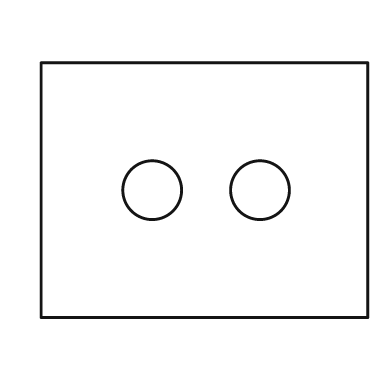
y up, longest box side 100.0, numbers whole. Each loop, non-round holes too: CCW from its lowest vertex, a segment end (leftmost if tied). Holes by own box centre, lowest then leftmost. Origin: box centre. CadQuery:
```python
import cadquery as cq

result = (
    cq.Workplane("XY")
    .moveTo(-50.0, -39.0)
    .lineTo(50.0, -39.0)
    .lineTo(50.0, 39.0)
    .lineTo(-50.0, 39.0)
    .close()
    .moveTo(-16.0, 0.0)
    .circle(9.0)
    .moveTo(17.0, 0.0)
    .circle(9.0)
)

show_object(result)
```